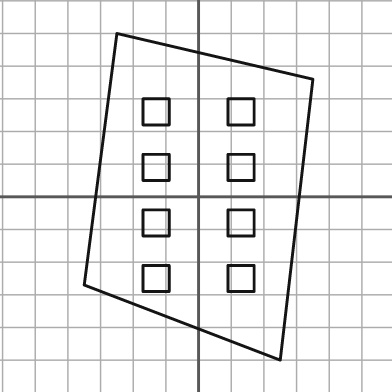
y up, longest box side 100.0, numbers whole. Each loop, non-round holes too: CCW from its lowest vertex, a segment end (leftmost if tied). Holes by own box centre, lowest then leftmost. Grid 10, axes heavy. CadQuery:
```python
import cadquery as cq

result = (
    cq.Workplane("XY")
    .moveTo(25.0, -50.0)
    .lineTo(35.0, 36.0)
    .lineTo(-25.0, 50.0)
    .lineTo(-35.0, -27.0)
    .close()
    .moveTo(-17.0, -29.0)
    .lineTo(-9.0, -29.0)
    .lineTo(-9.0, -21.0)
    .lineTo(-17.0, -21.0)
    .close()
    .moveTo(9.0, -29.0)
    .lineTo(17.0, -29.0)
    .lineTo(17.0, -21.0)
    .lineTo(9.0, -21.0)
    .close()
    .moveTo(-17.0, -12.0)
    .lineTo(-9.0, -12.0)
    .lineTo(-9.0, -4.0)
    .lineTo(-17.0, -4.0)
    .close()
    .moveTo(9.0, -12.0)
    .lineTo(17.0, -12.0)
    .lineTo(17.0, -4.0)
    .lineTo(9.0, -4.0)
    .close()
    .moveTo(-17.0, 5.0)
    .lineTo(-9.0, 5.0)
    .lineTo(-9.0, 13.0)
    .lineTo(-17.0, 13.0)
    .close()
    .moveTo(9.0, 5.0)
    .lineTo(17.0, 5.0)
    .lineTo(17.0, 13.0)
    .lineTo(9.0, 13.0)
    .close()
    .moveTo(-17.0, 22.0)
    .lineTo(-9.0, 22.0)
    .lineTo(-9.0, 30.0)
    .lineTo(-17.0, 30.0)
    .close()
    .moveTo(9.0, 22.0)
    .lineTo(17.0, 22.0)
    .lineTo(17.0, 30.0)
    .lineTo(9.0, 30.0)
    .close()
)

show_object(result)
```